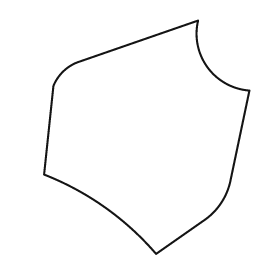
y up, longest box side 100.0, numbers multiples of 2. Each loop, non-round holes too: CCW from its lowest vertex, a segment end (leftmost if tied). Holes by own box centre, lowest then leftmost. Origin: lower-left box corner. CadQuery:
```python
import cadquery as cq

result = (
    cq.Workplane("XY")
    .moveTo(48.0, 0.0)
    .lineTo(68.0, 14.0)
    .threePointArc((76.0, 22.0), (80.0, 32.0))
    .lineTo(88.0, 70.0)
    .threePointArc((70.0, 80.0), (66.0, 100.0))
    .lineTo(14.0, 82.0)
    .threePointArc((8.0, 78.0), (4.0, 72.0))
    .lineTo(0.0, 34.0)
    .threePointArc((26.0, 20.0), (48.0, 0.0))
    .close()
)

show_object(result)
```